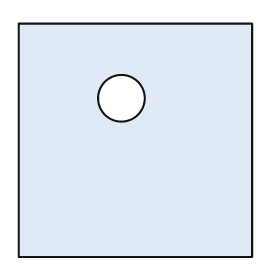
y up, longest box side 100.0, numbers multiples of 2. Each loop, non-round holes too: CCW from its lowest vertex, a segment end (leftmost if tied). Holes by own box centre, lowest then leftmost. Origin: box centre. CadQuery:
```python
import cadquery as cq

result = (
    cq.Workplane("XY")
    .moveTo(-50.0, -50.0)
    .lineTo(50.0, -50.0)
    .lineTo(50.0, 50.0)
    .lineTo(-50.0, 50.0)
    .close()
    .moveTo(-6.0, 18.0)
    .circle(10.0)
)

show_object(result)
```